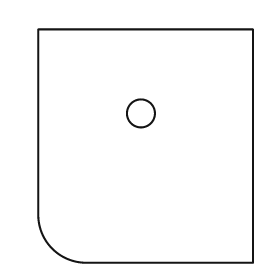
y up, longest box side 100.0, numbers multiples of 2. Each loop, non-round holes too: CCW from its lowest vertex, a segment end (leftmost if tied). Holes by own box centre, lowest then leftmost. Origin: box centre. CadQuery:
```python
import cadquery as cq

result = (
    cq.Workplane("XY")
    .moveTo(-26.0, -50.0)
    .lineTo(46.0, -50.0)
    .lineTo(46.0, 50.0)
    .lineTo(-46.0, 50.0)
    .lineTo(-46.0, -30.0)
    .threePointArc((-40.0, -44.0), (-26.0, -50.0))
    .close()
    .moveTo(-2.0, 14.0)
    .circle(6.0)
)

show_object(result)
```